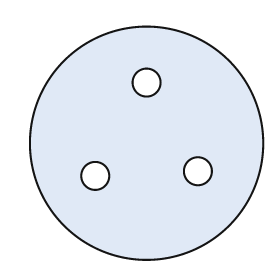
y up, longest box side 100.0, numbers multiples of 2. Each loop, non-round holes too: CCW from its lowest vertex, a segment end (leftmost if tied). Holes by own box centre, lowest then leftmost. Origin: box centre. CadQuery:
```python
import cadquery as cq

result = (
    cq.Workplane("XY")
    .moveTo(0.0, 0.0)
    .circle(50.0)
    .moveTo(-22.0, -14.0)
    .circle(6.0)
    .moveTo(22.0, -12.0)
    .circle(6.0)
    .moveTo(0.0, 26.0)
    .circle(6.0)
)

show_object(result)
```